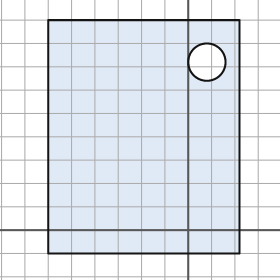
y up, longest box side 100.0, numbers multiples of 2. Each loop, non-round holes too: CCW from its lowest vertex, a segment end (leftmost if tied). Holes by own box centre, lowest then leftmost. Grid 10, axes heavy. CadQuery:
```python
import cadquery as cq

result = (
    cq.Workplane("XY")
    .moveTo(-60.0, -10.0)
    .lineTo(22.0, -10.0)
    .lineTo(22.0, 90.0)
    .lineTo(-60.0, 90.0)
    .close()
    .moveTo(8.0, 72.0)
    .circle(8.0)
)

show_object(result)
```